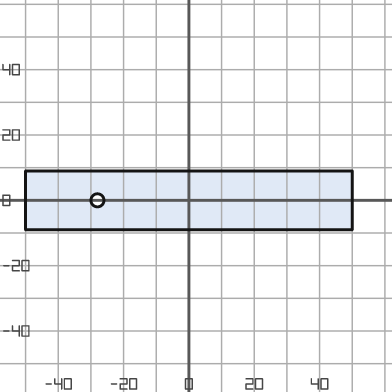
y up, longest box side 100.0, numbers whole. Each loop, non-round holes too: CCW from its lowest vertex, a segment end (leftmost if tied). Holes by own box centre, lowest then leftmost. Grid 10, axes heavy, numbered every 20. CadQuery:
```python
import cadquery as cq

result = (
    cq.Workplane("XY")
    .moveTo(-50.0, -9.0)
    .lineTo(50.0, -9.0)
    .lineTo(50.0, 9.0)
    .lineTo(-50.0, 9.0)
    .close()
    .moveTo(-28.0, 0.0)
    .circle(2.0)
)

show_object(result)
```